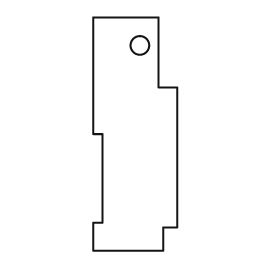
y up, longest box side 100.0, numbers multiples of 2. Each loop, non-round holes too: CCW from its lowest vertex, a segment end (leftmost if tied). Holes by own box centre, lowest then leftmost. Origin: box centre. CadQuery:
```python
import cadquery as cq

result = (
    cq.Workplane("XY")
    .moveTo(-18.0, -50.0)
    .lineTo(12.0, -50.0)
    .lineTo(12.0, -40.0)
    .lineTo(18.0, -40.0)
    .lineTo(18.0, 20.0)
    .lineTo(10.0, 20.0)
    .lineTo(10.0, 50.0)
    .lineTo(-18.0, 50.0)
    .lineTo(-18.0, 0.0)
    .lineTo(-14.0, 0.0)
    .lineTo(-14.0, -38.0)
    .lineTo(-18.0, -38.0)
    .close()
    .moveTo(2.0, 38.0)
    .circle(4.0)
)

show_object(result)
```